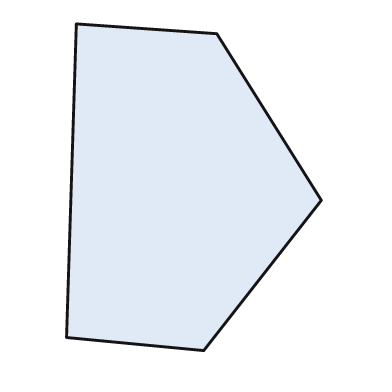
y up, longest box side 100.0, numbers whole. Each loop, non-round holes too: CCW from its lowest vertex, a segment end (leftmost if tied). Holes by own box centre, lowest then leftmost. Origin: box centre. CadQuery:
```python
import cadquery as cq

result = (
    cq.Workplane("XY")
    .moveTo(3.0, -50.0)
    .lineTo(39.0, -4.0)
    .lineTo(7.0, 47.0)
    .lineTo(-36.0, 50.0)
    .lineTo(-39.0, -46.0)
    .close()
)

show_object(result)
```